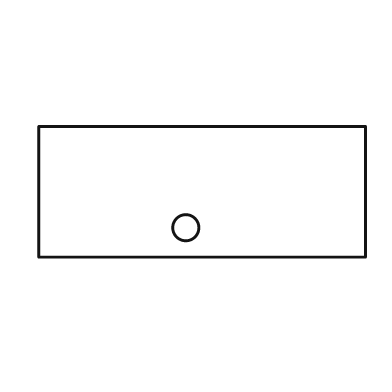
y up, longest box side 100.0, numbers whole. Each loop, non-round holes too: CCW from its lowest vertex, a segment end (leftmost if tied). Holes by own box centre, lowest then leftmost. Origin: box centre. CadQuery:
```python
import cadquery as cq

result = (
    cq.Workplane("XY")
    .moveTo(-50.0, -20.0)
    .lineTo(50.0, -20.0)
    .lineTo(50.0, 20.0)
    .lineTo(-50.0, 20.0)
    .close()
    .moveTo(-5.0, -11.0)
    .circle(4.0)
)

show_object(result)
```